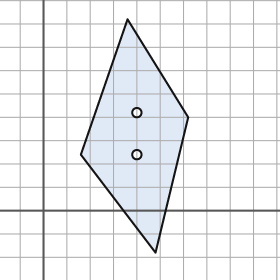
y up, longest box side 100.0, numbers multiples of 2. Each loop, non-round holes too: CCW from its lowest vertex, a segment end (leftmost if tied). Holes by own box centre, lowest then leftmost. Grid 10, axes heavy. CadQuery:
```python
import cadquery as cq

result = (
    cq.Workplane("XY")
    .moveTo(48.0, -18.0)
    .lineTo(62.0, 40.0)
    .lineTo(36.0, 82.0)
    .lineTo(16.0, 24.0)
    .close()
    .moveTo(40.0, 24.0)
    .circle(2.0)
    .moveTo(40.0, 42.0)
    .circle(2.0)
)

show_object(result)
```